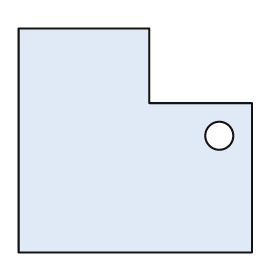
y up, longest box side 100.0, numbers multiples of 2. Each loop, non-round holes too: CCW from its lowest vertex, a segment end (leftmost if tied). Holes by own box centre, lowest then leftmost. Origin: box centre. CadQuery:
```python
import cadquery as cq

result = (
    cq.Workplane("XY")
    .moveTo(-50.0, -48.0)
    .lineTo(50.0, -48.0)
    .lineTo(50.0, 16.0)
    .lineTo(6.0, 16.0)
    .lineTo(6.0, 48.0)
    .lineTo(-50.0, 48.0)
    .close()
    .moveTo(36.0, 2.0)
    .circle(6.0)
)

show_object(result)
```